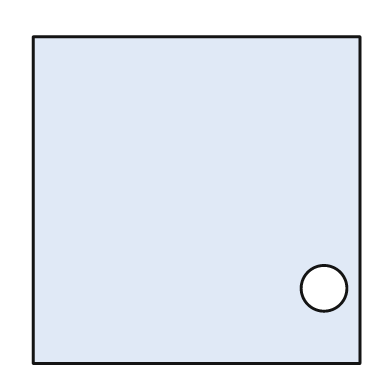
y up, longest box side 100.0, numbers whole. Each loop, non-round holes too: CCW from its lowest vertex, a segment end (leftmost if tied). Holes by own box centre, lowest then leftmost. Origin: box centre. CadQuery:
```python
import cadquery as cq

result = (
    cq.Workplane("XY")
    .moveTo(-50.0, -50.0)
    .lineTo(50.0, -50.0)
    .lineTo(50.0, 50.0)
    .lineTo(-50.0, 50.0)
    .close()
    .moveTo(39.0, -27.0)
    .circle(7.0)
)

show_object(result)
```